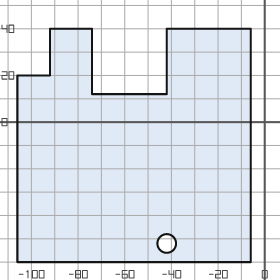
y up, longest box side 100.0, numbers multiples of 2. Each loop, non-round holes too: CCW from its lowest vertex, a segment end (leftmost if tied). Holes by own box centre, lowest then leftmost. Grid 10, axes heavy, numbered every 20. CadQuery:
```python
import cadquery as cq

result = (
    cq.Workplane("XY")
    .moveTo(-106.0, -60.0)
    .lineTo(-6.0, -60.0)
    .lineTo(-6.0, 40.0)
    .lineTo(-42.0, 40.0)
    .lineTo(-42.0, 12.0)
    .lineTo(-74.0, 12.0)
    .lineTo(-74.0, 40.0)
    .lineTo(-92.0, 40.0)
    .lineTo(-92.0, 20.0)
    .lineTo(-106.0, 20.0)
    .close()
    .moveTo(-42.0, -52.0)
    .circle(4.0)
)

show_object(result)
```